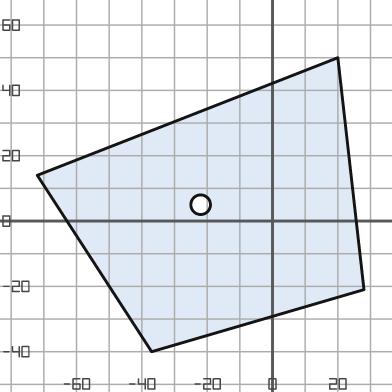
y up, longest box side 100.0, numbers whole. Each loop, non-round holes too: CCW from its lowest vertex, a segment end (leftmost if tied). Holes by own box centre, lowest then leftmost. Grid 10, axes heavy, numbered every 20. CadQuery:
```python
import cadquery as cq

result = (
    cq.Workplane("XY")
    .moveTo(-37.0, -40.0)
    .lineTo(28.0, -21.0)
    .lineTo(20.0, 50.0)
    .lineTo(-72.0, 14.0)
    .close()
    .moveTo(-22.0, 5.0)
    .circle(3.0)
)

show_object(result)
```